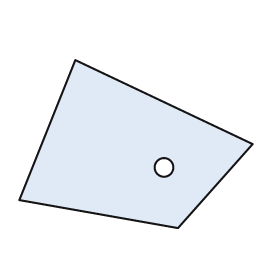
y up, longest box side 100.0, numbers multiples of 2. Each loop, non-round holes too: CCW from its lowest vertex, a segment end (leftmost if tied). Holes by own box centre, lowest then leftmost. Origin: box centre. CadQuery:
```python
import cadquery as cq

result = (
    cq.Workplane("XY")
    .moveTo(18.0, -36.0)
    .lineTo(50.0, 0.0)
    .lineTo(-26.0, 36.0)
    .lineTo(-50.0, -24.0)
    .close()
    .moveTo(12.0, -10.0)
    .circle(4.0)
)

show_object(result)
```